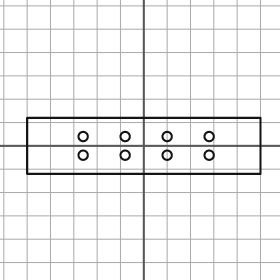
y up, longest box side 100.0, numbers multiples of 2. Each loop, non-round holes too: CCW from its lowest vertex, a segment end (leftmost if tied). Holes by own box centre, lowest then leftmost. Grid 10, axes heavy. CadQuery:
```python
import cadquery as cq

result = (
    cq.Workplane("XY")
    .moveTo(-50.0, -12.0)
    .lineTo(50.0, -12.0)
    .lineTo(50.0, 12.0)
    .lineTo(-50.0, 12.0)
    .close()
    .moveTo(-26.0, -4.0)
    .circle(2.0)
    .moveTo(-8.0, -4.0)
    .circle(2.0)
    .moveTo(10.0, -4.0)
    .circle(2.0)
    .moveTo(28.0, -4.0)
    .circle(2.0)
    .moveTo(-26.0, 4.0)
    .circle(2.0)
    .moveTo(-8.0, 4.0)
    .circle(2.0)
    .moveTo(10.0, 4.0)
    .circle(2.0)
    .moveTo(28.0, 4.0)
    .circle(2.0)
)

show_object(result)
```